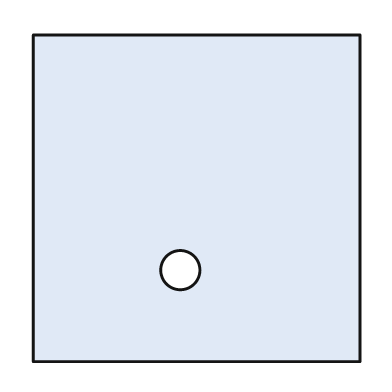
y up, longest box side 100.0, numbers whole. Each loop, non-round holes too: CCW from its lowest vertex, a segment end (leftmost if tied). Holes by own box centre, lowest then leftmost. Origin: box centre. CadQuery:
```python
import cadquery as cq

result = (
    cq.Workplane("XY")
    .moveTo(-50.0, -50.0)
    .lineTo(50.0, -50.0)
    .lineTo(50.0, 50.0)
    .lineTo(-50.0, 50.0)
    .close()
    .moveTo(-5.0, -22.0)
    .circle(6.0)
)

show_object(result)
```